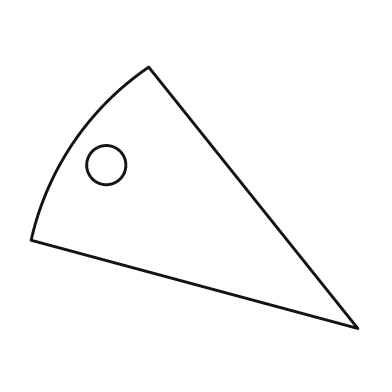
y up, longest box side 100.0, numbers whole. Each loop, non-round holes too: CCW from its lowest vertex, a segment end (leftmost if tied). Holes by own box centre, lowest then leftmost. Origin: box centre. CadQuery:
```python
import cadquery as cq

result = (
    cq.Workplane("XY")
    .moveTo(50.0, -40.0)
    .lineTo(-14.0, 40.0)
    .threePointArc((-37.0, 17.0), (-50.0, -13.0))
    .close()
    .moveTo(-27.0, 10.0)
    .circle(6.0)
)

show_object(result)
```